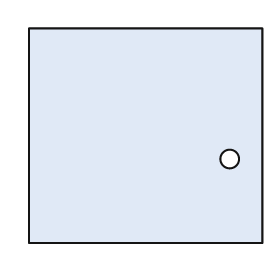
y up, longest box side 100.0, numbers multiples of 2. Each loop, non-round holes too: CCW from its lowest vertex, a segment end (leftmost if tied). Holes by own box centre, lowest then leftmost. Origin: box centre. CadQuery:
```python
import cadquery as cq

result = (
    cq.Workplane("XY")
    .moveTo(-50.0, -46.0)
    .lineTo(50.0, -46.0)
    .lineTo(50.0, 46.0)
    .lineTo(-50.0, 46.0)
    .close()
    .moveTo(36.0, -10.0)
    .circle(4.0)
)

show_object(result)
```